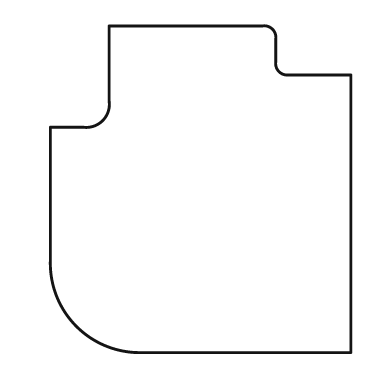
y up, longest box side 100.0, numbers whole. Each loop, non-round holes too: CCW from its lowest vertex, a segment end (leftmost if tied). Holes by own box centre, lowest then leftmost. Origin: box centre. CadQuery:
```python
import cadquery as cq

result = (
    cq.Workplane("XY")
    .moveTo(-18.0, -50.0)
    .lineTo(46.0, -50.0)
    .lineTo(46.0, 35.0)
    .lineTo(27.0, 35.0)
    .threePointArc((24.0, 36.0), (23.0, 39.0))
    .lineTo(23.0, 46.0)
    .threePointArc((22.0, 49.0), (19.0, 50.0))
    .lineTo(-28.0, 50.0)
    .lineTo(-28.0, 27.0)
    .threePointArc((-30.0, 21.0), (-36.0, 19.0))
    .lineTo(-46.0, 19.0)
    .lineTo(-46.0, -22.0)
    .threePointArc((-38.0, -42.0), (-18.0, -50.0))
    .close()
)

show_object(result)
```